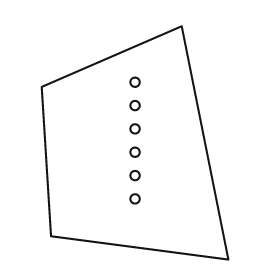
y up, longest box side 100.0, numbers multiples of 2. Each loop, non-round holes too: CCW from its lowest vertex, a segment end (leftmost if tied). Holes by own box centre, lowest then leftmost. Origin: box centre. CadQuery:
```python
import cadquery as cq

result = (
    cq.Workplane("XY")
    .moveTo(40.0, -50.0)
    .lineTo(20.0, 50.0)
    .lineTo(-40.0, 24.0)
    .lineTo(-36.0, -40.0)
    .close()
    .moveTo(0.0, -24.0)
    .circle(2.0)
    .moveTo(0.0, -14.0)
    .circle(2.0)
    .moveTo(0.0, -4.0)
    .circle(2.0)
    .moveTo(0.0, 6.0)
    .circle(2.0)
    .moveTo(0.0, 16.0)
    .circle(2.0)
    .moveTo(0.0, 26.0)
    .circle(2.0)
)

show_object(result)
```